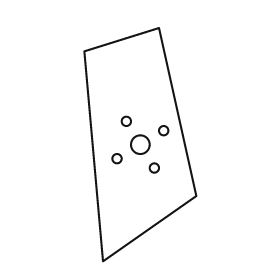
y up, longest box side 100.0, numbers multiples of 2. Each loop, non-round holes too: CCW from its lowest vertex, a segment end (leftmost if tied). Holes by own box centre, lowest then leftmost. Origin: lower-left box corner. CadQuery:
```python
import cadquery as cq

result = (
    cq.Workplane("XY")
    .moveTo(8.0, 0.0)
    .lineTo(48.0, 28.0)
    .lineTo(32.0, 100.0)
    .lineTo(0.0, 90.0)
    .close()
    .moveTo(30.0, 40.0)
    .circle(2.0)
    .moveTo(14.0, 44.0)
    .circle(2.0)
    .moveTo(24.0, 50.0)
    .circle(4.0)
    .moveTo(34.0, 56.0)
    .circle(2.0)
    .moveTo(18.0, 60.0)
    .circle(2.0)
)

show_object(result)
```